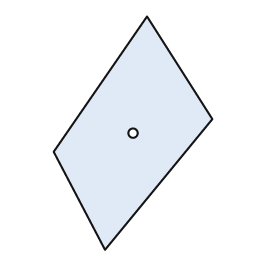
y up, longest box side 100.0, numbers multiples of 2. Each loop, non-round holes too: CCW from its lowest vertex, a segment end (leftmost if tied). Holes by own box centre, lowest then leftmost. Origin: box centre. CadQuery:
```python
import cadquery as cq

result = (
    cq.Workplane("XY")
    .moveTo(-12.0, -50.0)
    .lineTo(34.0, 6.0)
    .lineTo(6.0, 50.0)
    .lineTo(-34.0, -8.0)
    .close()
    .moveTo(0.0, 0.0)
    .circle(2.0)
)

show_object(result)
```